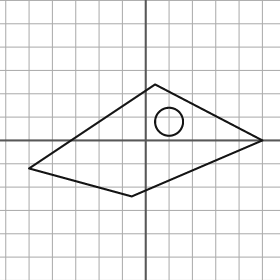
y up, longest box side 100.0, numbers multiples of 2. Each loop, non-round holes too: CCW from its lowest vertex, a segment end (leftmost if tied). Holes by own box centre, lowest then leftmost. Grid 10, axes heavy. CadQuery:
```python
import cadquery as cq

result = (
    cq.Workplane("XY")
    .moveTo(-6.0, -24.0)
    .lineTo(50.0, 0.0)
    .lineTo(4.0, 24.0)
    .lineTo(-50.0, -12.0)
    .close()
    .moveTo(10.0, 8.0)
    .circle(6.0)
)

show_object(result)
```